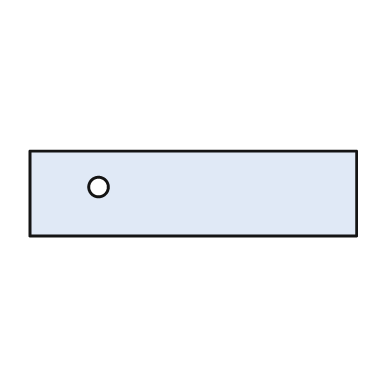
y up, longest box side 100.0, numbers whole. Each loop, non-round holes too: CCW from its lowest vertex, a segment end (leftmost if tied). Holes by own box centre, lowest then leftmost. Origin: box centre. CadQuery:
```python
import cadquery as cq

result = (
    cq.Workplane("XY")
    .moveTo(-50.0, -13.0)
    .lineTo(50.0, -13.0)
    .lineTo(50.0, 13.0)
    .lineTo(-50.0, 13.0)
    .close()
    .moveTo(-29.0, 2.0)
    .circle(3.0)
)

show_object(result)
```